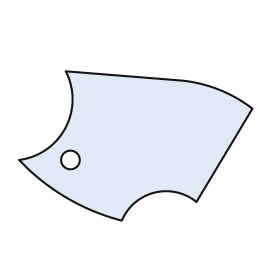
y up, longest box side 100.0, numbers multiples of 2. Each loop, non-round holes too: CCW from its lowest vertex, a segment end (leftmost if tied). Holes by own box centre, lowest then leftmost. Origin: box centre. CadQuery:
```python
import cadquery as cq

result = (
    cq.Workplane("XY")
    .moveTo(-6.0, -32.0)
    .threePointArc((8.0, -20.0), (26.0, -24.0))
    .lineTo(50.0, 16.0)
    .threePointArc((36.0, 24.0), (20.0, 28.0))
    .lineTo(-30.0, 32.0)
    .threePointArc((-30.0, 8.0), (-50.0, -6.0))
    .threePointArc((-30.0, -22.0), (-6.0, -32.0))
    .close()
    .moveTo(-28.0, -6.0)
    .circle(4.0)
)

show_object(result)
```